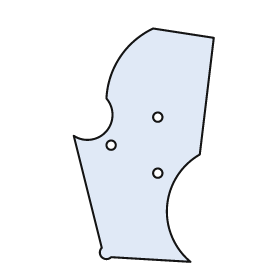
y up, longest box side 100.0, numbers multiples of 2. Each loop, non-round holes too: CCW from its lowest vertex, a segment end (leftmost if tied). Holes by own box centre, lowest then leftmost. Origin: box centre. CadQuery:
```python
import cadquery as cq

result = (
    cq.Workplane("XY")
    .moveTo(20.0, -50.0)
    .threePointArc((10.0, -26.0), (24.0, -4.0))
    .lineTo(30.0, 46.0)
    .lineTo(4.0, 50.0)
    .threePointArc((-10.0, 38.0), (-16.0, 20.0))
    .threePointArc((-16.0, 6.0), (-30.0, 4.0))
    .lineTo(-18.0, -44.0)
    .threePointArc((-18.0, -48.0), (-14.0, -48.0))
    .close()
    .moveTo(6.0, -12.0)
    .circle(2.0)
    .moveTo(-14.0, 0.0)
    .circle(2.0)
    .moveTo(6.0, 12.0)
    .circle(2.0)
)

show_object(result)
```